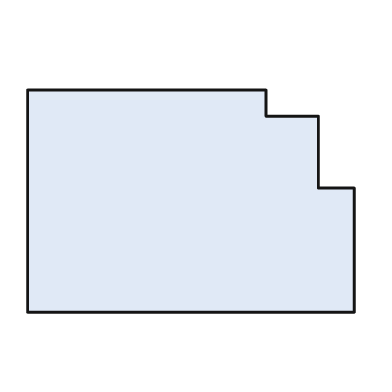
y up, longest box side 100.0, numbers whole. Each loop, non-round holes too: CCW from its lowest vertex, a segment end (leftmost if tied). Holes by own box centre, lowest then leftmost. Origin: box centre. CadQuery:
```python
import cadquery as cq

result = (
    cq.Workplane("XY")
    .moveTo(-50.0, -34.0)
    .lineTo(50.0, -34.0)
    .lineTo(50.0, 4.0)
    .lineTo(39.0, 4.0)
    .lineTo(39.0, 26.0)
    .lineTo(23.0, 26.0)
    .lineTo(23.0, 34.0)
    .lineTo(-50.0, 34.0)
    .close()
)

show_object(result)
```